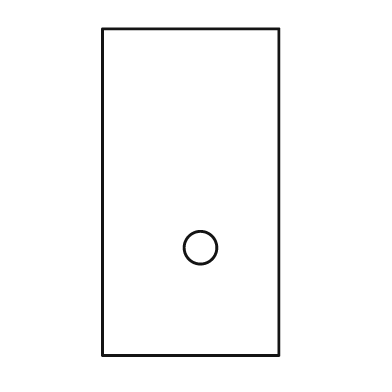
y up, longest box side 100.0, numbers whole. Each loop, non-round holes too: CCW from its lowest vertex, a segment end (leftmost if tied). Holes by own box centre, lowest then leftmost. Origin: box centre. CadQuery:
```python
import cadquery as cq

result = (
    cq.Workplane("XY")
    .moveTo(-27.0, -50.0)
    .lineTo(27.0, -50.0)
    .lineTo(27.0, 50.0)
    .lineTo(-27.0, 50.0)
    .close()
    .moveTo(3.0, -17.0)
    .circle(5.0)
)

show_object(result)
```